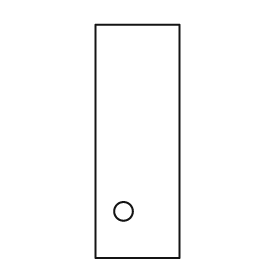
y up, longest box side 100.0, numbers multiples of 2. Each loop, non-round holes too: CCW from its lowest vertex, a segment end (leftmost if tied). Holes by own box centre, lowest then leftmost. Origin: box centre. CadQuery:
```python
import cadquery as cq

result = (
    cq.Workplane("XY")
    .moveTo(-18.0, -50.0)
    .lineTo(18.0, -50.0)
    .lineTo(18.0, 50.0)
    .lineTo(-18.0, 50.0)
    .close()
    .moveTo(-6.0, -30.0)
    .circle(4.0)
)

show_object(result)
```